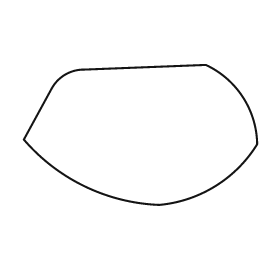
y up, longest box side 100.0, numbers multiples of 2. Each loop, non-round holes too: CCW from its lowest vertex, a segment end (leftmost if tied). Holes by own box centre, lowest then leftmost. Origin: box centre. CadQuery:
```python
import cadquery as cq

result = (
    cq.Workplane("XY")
    .moveTo(8.0, -30.0)
    .threePointArc((32.0, -22.0), (50.0, -4.0))
    .threePointArc((44.0, 16.0), (28.0, 30.0))
    .lineTo(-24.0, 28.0)
    .threePointArc((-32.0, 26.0), (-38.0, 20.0))
    .lineTo(-50.0, -2.0)
    .threePointArc((-24.0, -22.0), (8.0, -30.0))
    .close()
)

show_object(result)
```